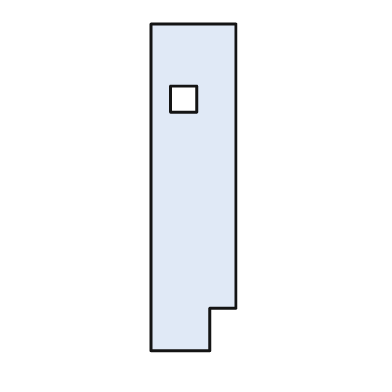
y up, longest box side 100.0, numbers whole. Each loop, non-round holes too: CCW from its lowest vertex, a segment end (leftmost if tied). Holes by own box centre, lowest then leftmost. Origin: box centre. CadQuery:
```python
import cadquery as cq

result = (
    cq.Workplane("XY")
    .moveTo(-13.0, -50.0)
    .lineTo(5.0, -50.0)
    .lineTo(5.0, -37.0)
    .lineTo(13.0, -37.0)
    .lineTo(13.0, 50.0)
    .lineTo(-13.0, 50.0)
    .close()
    .moveTo(-7.0, 23.0)
    .lineTo(1.0, 23.0)
    .lineTo(1.0, 31.0)
    .lineTo(-7.0, 31.0)
    .close()
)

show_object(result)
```